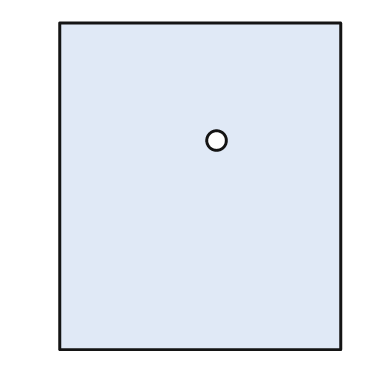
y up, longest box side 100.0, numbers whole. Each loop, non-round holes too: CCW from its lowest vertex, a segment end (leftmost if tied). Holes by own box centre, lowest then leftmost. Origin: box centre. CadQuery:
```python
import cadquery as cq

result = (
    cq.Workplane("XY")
    .moveTo(-43.0, -50.0)
    .lineTo(43.0, -50.0)
    .lineTo(43.0, 50.0)
    .lineTo(-43.0, 50.0)
    .close()
    .moveTo(5.0, 14.0)
    .circle(3.0)
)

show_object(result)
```